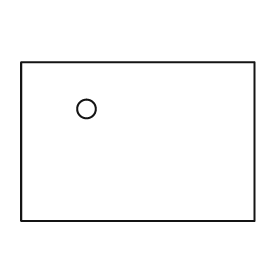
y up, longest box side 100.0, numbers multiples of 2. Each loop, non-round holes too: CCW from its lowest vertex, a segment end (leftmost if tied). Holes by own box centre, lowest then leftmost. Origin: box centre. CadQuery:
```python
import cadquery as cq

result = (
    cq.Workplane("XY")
    .moveTo(-50.0, -34.0)
    .lineTo(50.0, -34.0)
    .lineTo(50.0, 34.0)
    .lineTo(-50.0, 34.0)
    .close()
    .moveTo(-22.0, 14.0)
    .circle(4.0)
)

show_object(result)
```